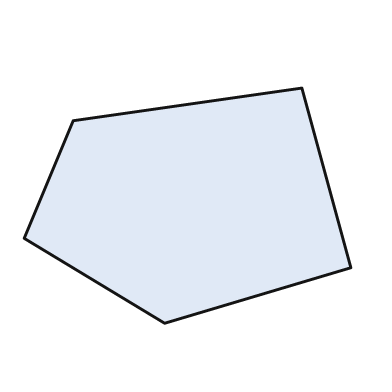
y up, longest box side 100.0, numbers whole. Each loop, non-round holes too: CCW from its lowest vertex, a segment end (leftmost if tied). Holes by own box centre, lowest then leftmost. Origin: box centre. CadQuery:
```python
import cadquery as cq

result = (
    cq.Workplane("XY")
    .moveTo(-7.0, -36.0)
    .lineTo(50.0, -19.0)
    .lineTo(35.0, 36.0)
    .lineTo(-35.0, 26.0)
    .lineTo(-50.0, -10.0)
    .close()
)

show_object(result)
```